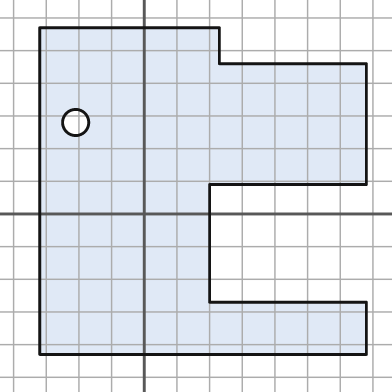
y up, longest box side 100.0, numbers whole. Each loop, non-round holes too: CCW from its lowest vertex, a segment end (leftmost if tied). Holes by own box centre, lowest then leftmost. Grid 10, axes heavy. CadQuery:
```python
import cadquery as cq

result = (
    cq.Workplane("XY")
    .moveTo(-32.0, -43.0)
    .lineTo(68.0, -43.0)
    .lineTo(68.0, -27.0)
    .lineTo(20.0, -27.0)
    .lineTo(20.0, 9.0)
    .lineTo(68.0, 9.0)
    .lineTo(68.0, 46.0)
    .lineTo(23.0, 46.0)
    .lineTo(23.0, 57.0)
    .lineTo(-32.0, 57.0)
    .close()
    .moveTo(-21.0, 28.0)
    .circle(4.0)
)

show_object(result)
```